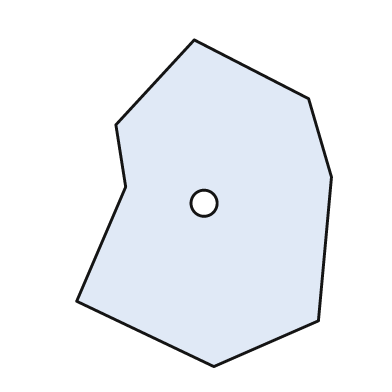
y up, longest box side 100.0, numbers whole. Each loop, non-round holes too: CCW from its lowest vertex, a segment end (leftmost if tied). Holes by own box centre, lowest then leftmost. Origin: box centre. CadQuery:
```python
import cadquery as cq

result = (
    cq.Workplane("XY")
    .moveTo(3.0, -50.0)
    .lineTo(35.0, -36.0)
    .lineTo(39.0, 8.0)
    .lineTo(32.0, 32.0)
    .lineTo(-3.0, 50.0)
    .lineTo(-27.0, 24.0)
    .lineTo(-24.0, 5.0)
    .lineTo(-39.0, -30.0)
    .close()
    .moveTo(0.0, 0.0)
    .circle(4.0)
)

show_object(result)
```